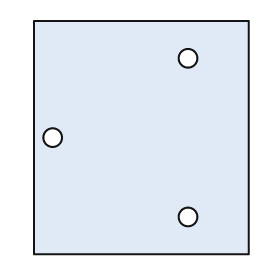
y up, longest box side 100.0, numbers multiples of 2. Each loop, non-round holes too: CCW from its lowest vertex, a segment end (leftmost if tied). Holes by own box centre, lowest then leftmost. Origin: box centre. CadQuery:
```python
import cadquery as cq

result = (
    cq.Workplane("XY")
    .moveTo(-46.0, -50.0)
    .lineTo(46.0, -50.0)
    .lineTo(46.0, 50.0)
    .lineTo(-46.0, 50.0)
    .close()
    .moveTo(20.0, -34.0)
    .circle(4.0)
    .moveTo(-38.0, 0.0)
    .circle(4.0)
    .moveTo(20.0, 34.0)
    .circle(4.0)
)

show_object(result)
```